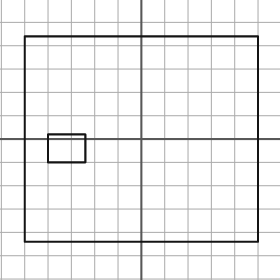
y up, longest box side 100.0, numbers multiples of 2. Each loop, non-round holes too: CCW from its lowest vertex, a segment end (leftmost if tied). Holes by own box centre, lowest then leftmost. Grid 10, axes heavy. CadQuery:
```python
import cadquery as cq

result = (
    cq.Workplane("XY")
    .moveTo(-50.0, -44.0)
    .lineTo(50.0, -44.0)
    .lineTo(50.0, 44.0)
    .lineTo(-50.0, 44.0)
    .close()
    .moveTo(-40.0, -10.0)
    .lineTo(-24.0, -10.0)
    .lineTo(-24.0, 2.0)
    .lineTo(-40.0, 2.0)
    .close()
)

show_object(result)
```